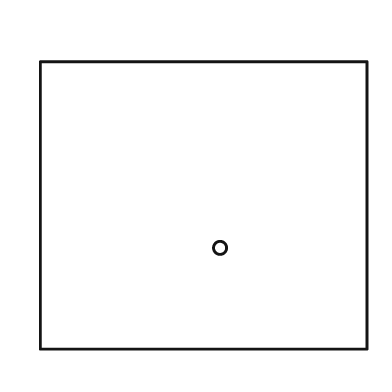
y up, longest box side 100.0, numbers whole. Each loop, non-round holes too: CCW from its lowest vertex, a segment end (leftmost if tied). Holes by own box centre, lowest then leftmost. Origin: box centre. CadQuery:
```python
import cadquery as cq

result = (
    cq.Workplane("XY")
    .moveTo(-50.0, -44.0)
    .lineTo(50.0, -44.0)
    .lineTo(50.0, 44.0)
    .lineTo(-50.0, 44.0)
    .close()
    .moveTo(5.0, -13.0)
    .circle(2.0)
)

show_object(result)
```